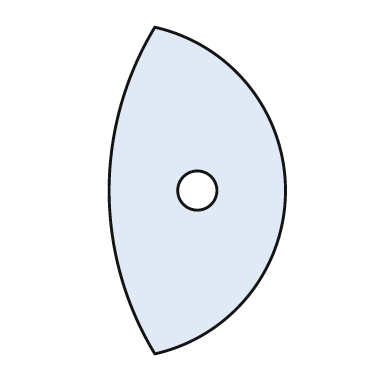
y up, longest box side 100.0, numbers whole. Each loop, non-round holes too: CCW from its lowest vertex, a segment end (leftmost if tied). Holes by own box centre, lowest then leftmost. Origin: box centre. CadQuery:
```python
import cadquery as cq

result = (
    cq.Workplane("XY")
    .moveTo(-13.0, -50.0)
    .threePointArc((27.0, 0.0), (-13.0, 50.0))
    .threePointArc((-27.0, 0.0), (-13.0, -50.0))
    .close()
    .moveTo(0.0, 0.0)
    .circle(6.0)
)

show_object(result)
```